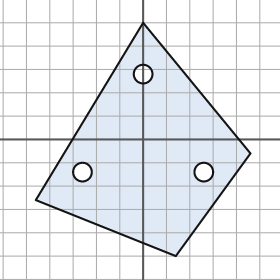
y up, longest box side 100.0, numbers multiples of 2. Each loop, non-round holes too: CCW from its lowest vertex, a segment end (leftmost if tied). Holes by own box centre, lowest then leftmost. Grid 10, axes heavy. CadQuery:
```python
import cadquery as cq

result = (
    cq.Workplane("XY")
    .moveTo(14.0, -50.0)
    .lineTo(46.0, -6.0)
    .lineTo(0.0, 50.0)
    .lineTo(-46.0, -26.0)
    .close()
    .moveTo(-26.0, -14.0)
    .circle(4.0)
    .moveTo(26.0, -14.0)
    .circle(4.0)
    .moveTo(0.0, 28.0)
    .circle(4.0)
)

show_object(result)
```